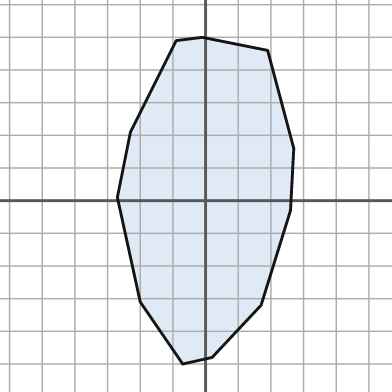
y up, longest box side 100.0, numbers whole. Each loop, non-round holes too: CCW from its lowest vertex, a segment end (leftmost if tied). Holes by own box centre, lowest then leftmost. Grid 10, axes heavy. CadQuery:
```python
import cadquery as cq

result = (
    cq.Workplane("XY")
    .moveTo(-7.0, -50.0)
    .lineTo(2.0, -48.0)
    .lineTo(17.0, -32.0)
    .lineTo(26.0, -3.0)
    .lineTo(27.0, 16.0)
    .lineTo(19.0, 46.0)
    .lineTo(-1.0, 50.0)
    .lineTo(-9.0, 49.0)
    .lineTo(-23.0, 21.0)
    .lineTo(-27.0, 1.0)
    .lineTo(-20.0, -31.0)
    .close()
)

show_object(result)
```